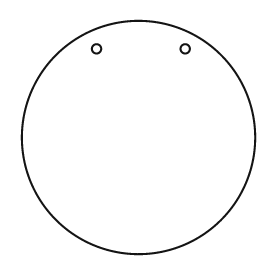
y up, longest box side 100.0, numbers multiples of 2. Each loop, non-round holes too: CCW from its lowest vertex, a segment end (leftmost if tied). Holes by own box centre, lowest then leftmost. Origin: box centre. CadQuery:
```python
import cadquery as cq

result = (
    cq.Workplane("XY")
    .moveTo(0.0, 0.0)
    .circle(50.0)
    .moveTo(-18.0, 38.0)
    .circle(2.0)
    .moveTo(20.0, 38.0)
    .circle(2.0)
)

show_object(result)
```